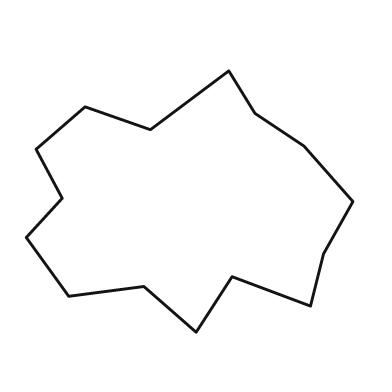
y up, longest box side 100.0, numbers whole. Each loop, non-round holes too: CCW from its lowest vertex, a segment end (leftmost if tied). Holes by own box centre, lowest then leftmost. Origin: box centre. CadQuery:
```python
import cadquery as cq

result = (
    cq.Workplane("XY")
    .moveTo(2.0, -40.0)
    .lineTo(13.0, -23.0)
    .lineTo(37.0, -32.0)
    .lineTo(41.0, -16.0)
    .lineTo(50.0, 0.0)
    .lineTo(35.0, 17.0)
    .lineTo(20.0, 27.0)
    .lineTo(12.0, 40.0)
    .lineTo(-12.0, 22.0)
    .lineTo(-32.0, 29.0)
    .lineTo(-47.0, 16.0)
    .lineTo(-39.0, 1.0)
    .lineTo(-50.0, -11.0)
    .lineTo(-37.0, -29.0)
    .lineTo(-14.0, -26.0)
    .close()
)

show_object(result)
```